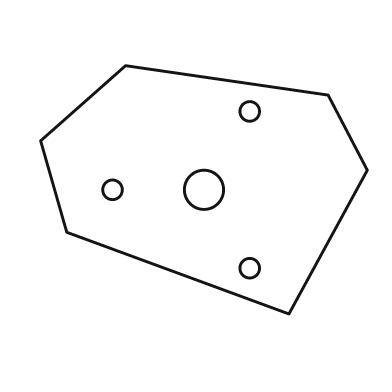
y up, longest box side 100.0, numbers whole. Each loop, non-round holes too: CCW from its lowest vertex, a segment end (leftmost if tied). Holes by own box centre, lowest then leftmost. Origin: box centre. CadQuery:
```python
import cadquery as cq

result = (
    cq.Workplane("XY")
    .moveTo(26.0, -38.0)
    .lineTo(50.0, 6.0)
    .lineTo(38.0, 29.0)
    .lineTo(-24.0, 38.0)
    .lineTo(-50.0, 15.0)
    .lineTo(-42.0, -13.0)
    .close()
    .moveTo(14.0, -24.0)
    .circle(3.0)
    .moveTo(-28.0, 0.0)
    .circle(3.0)
    .moveTo(0.0, 0.0)
    .circle(6.0)
    .moveTo(14.0, 24.0)
    .circle(3.0)
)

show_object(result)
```